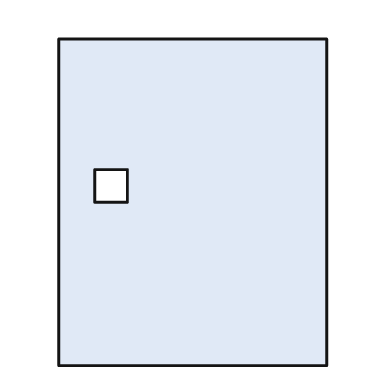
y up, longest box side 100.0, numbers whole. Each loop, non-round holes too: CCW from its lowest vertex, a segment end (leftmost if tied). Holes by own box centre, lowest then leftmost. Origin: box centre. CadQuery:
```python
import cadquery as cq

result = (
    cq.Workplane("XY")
    .moveTo(-41.0, -50.0)
    .lineTo(41.0, -50.0)
    .lineTo(41.0, 50.0)
    .lineTo(-41.0, 50.0)
    .close()
    .moveTo(-30.0, 0.0)
    .lineTo(-20.0, 0.0)
    .lineTo(-20.0, 10.0)
    .lineTo(-30.0, 10.0)
    .close()
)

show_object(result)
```